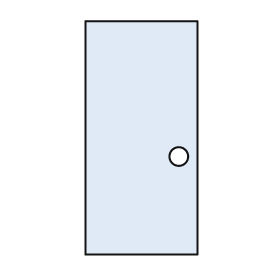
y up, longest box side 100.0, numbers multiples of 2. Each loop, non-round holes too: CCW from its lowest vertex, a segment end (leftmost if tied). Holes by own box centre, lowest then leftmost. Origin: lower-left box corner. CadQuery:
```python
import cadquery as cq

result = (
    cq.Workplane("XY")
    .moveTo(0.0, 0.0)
    .lineTo(48.0, 0.0)
    .lineTo(48.0, 100.0)
    .lineTo(0.0, 100.0)
    .close()
    .moveTo(40.0, 42.0)
    .circle(4.0)
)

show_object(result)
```